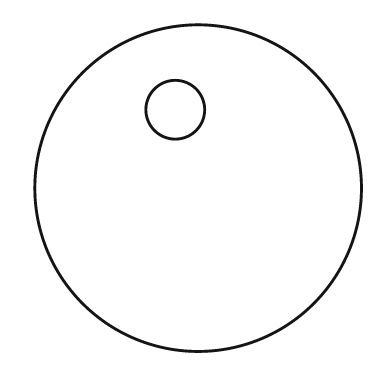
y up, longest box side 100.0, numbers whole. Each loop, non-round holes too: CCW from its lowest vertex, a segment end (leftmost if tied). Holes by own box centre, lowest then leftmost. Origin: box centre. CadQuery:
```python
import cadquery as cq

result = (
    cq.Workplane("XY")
    .moveTo(0.0, 0.0)
    .circle(50.0)
    .moveTo(-7.0, 24.0)
    .circle(9.0)
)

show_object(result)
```